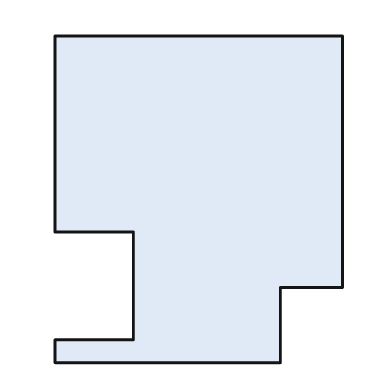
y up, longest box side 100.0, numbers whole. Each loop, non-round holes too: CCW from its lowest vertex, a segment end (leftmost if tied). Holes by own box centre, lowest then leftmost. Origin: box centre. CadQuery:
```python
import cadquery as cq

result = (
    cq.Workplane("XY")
    .moveTo(-44.0, -50.0)
    .lineTo(25.0, -50.0)
    .lineTo(25.0, -27.0)
    .lineTo(44.0, -27.0)
    .lineTo(44.0, 50.0)
    .lineTo(-44.0, 50.0)
    .lineTo(-44.0, -10.0)
    .lineTo(-20.0, -10.0)
    .lineTo(-20.0, -43.0)
    .lineTo(-44.0, -43.0)
    .close()
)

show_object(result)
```